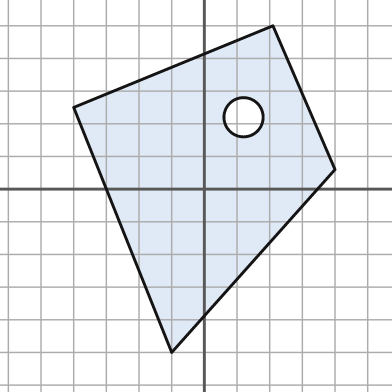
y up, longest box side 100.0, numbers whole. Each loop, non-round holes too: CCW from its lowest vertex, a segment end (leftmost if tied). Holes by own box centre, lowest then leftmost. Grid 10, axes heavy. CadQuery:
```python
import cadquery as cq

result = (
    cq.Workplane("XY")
    .moveTo(-10.0, -50.0)
    .lineTo(40.0, 6.0)
    .lineTo(21.0, 50.0)
    .lineTo(-40.0, 25.0)
    .close()
    .moveTo(12.0, 22.0)
    .circle(6.0)
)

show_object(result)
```